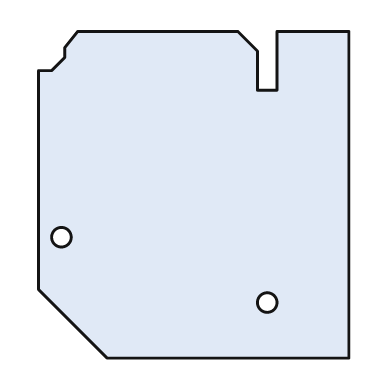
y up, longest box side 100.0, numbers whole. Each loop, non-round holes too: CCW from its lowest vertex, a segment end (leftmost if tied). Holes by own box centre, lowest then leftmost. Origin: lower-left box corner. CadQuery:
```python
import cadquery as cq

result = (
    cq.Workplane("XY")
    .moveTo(21.0, 0.0)
    .lineTo(95.0, 0.0)
    .lineTo(95.0, 100.0)
    .lineTo(73.0, 100.0)
    .lineTo(73.0, 82.0)
    .lineTo(67.0, 82.0)
    .lineTo(67.0, 94.0)
    .lineTo(61.0, 100.0)
    .lineTo(12.0, 100.0)
    .lineTo(8.0, 95.0)
    .lineTo(8.0, 92.0)
    .lineTo(4.0, 88.0)
    .lineTo(0.0, 88.0)
    .lineTo(0.0, 21.0)
    .close()
    .moveTo(70.0, 17.0)
    .circle(3.0)
    .moveTo(7.0, 37.0)
    .circle(3.0)
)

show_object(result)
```